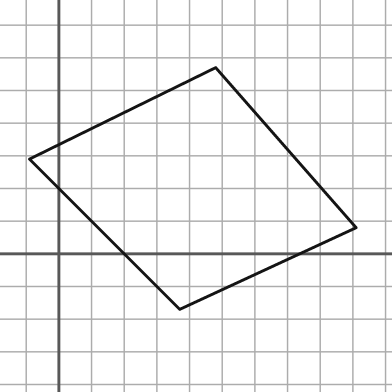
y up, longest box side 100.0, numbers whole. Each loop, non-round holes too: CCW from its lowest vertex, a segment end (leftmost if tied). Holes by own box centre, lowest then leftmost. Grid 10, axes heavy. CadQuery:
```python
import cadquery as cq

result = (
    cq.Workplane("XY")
    .moveTo(37.0, -17.0)
    .lineTo(91.0, 8.0)
    .lineTo(48.0, 57.0)
    .lineTo(-9.0, 29.0)
    .close()
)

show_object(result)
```